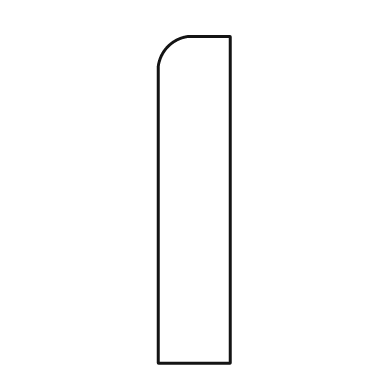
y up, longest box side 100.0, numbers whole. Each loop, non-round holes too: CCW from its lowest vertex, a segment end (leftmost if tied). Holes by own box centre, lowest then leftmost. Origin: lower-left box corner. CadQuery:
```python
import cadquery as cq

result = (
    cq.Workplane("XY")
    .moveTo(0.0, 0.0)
    .lineTo(22.0, 0.0)
    .lineTo(22.0, 100.0)
    .lineTo(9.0, 100.0)
    .threePointArc((3.0, 97.0), (0.0, 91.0))
    .close()
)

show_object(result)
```